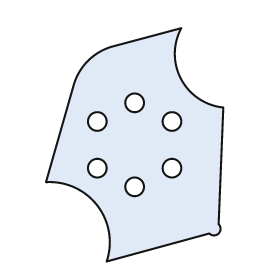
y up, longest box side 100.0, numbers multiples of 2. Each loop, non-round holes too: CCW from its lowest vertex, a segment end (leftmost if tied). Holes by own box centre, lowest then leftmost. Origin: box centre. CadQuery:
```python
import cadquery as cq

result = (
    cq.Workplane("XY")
    .moveTo(-12.0, -50.0)
    .lineTo(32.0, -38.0)
    .threePointArc((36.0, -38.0), (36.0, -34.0))
    .lineTo(38.0, 16.0)
    .threePointArc((20.0, 28.0), (20.0, 50.0))
    .lineTo(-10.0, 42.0)
    .threePointArc((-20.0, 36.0), (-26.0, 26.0))
    .lineTo(-38.0, -16.0)
    .threePointArc((-16.0, -26.0), (-12.0, -50.0))
    .close()
    .moveTo(0.0, -18.0)
    .circle(4.0)
    .moveTo(-16.0, -10.0)
    .circle(4.0)
    .moveTo(16.0, -10.0)
    .circle(4.0)
    .moveTo(-16.0, 10.0)
    .circle(4.0)
    .moveTo(16.0, 10.0)
    .circle(4.0)
    .moveTo(0.0, 18.0)
    .circle(4.0)
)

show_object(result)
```